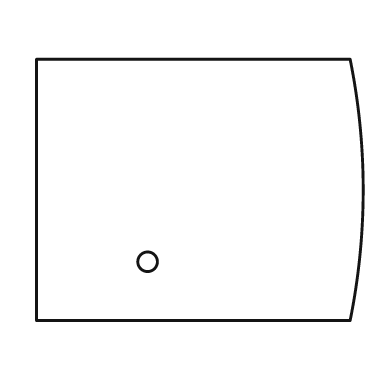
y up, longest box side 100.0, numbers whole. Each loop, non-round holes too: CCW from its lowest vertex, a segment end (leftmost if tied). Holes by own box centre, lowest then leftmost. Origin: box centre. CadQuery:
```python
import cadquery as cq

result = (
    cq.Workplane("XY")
    .moveTo(-50.0, -40.0)
    .lineTo(46.0, -40.0)
    .threePointArc((50.0, 0.0), (46.0, 40.0))
    .lineTo(-50.0, 40.0)
    .close()
    .moveTo(-16.0, -22.0)
    .circle(3.0)
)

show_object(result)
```